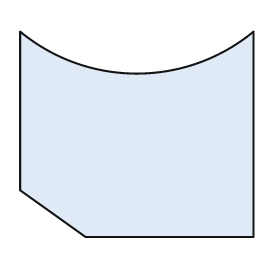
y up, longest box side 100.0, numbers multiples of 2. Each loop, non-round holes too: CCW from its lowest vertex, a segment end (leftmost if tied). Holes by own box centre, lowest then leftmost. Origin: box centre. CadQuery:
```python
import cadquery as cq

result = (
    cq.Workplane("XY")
    .moveTo(-22.0, -44.0)
    .lineTo(50.0, -44.0)
    .lineTo(50.0, 44.0)
    .threePointArc((0.0, 26.0), (-50.0, 44.0))
    .lineTo(-50.0, -24.0)
    .close()
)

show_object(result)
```